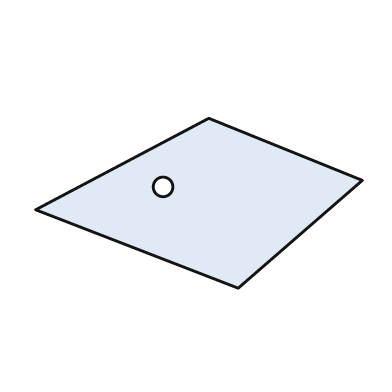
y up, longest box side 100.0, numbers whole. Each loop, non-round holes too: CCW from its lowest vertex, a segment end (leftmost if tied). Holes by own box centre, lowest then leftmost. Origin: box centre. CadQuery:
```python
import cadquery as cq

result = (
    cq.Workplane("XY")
    .moveTo(12.0, -26.0)
    .lineTo(50.0, 7.0)
    .lineTo(3.0, 26.0)
    .lineTo(-50.0, -2.0)
    .close()
    .moveTo(-11.0, 5.0)
    .circle(3.0)
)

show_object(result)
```